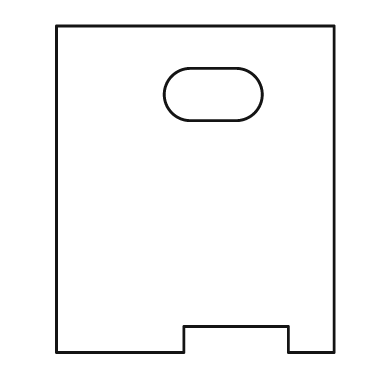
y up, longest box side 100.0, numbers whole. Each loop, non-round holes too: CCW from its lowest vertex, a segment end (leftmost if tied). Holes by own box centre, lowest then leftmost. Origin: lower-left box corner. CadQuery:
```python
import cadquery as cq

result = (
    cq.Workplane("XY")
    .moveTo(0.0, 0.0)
    .lineTo(39.0, 0.0)
    .lineTo(39.0, 8.0)
    .lineTo(71.0, 8.0)
    .lineTo(71.0, 0.0)
    .lineTo(85.0, 0.0)
    .lineTo(85.0, 100.0)
    .lineTo(0.0, 100.0)
    .close()
    .moveTo(41.0, 71.0)
    .lineTo(55.0, 71.0)
    .threePointArc((63.0, 79.0), (55.0, 87.0))
    .lineTo(41.0, 87.0)
    .threePointArc((33.0, 79.0), (41.0, 71.0))
    .close()
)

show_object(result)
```